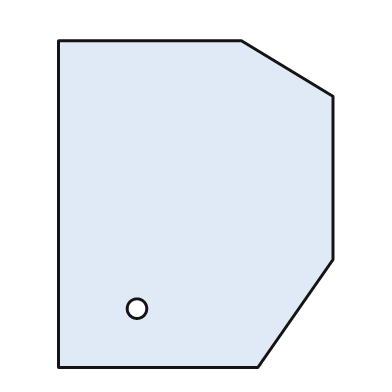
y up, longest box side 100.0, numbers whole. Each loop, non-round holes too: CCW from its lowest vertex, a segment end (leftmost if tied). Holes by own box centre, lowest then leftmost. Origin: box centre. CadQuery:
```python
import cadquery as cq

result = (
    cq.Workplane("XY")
    .moveTo(-42.0, -50.0)
    .lineTo(19.0, -50.0)
    .lineTo(42.0, -17.0)
    .lineTo(42.0, 33.0)
    .lineTo(14.0, 50.0)
    .lineTo(-42.0, 50.0)
    .close()
    .moveTo(-18.0, -32.0)
    .circle(3.0)
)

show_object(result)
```